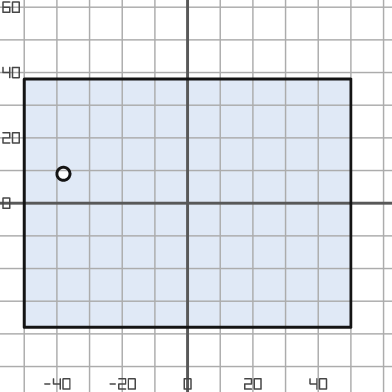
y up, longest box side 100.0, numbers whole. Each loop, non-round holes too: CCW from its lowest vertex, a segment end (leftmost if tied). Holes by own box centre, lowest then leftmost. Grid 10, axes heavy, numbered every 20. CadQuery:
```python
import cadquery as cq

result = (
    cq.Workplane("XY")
    .moveTo(-50.0, -38.0)
    .lineTo(50.0, -38.0)
    .lineTo(50.0, 38.0)
    .lineTo(-50.0, 38.0)
    .close()
    .moveTo(-38.0, 9.0)
    .circle(2.0)
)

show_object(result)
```